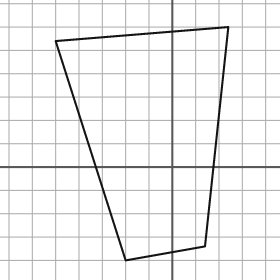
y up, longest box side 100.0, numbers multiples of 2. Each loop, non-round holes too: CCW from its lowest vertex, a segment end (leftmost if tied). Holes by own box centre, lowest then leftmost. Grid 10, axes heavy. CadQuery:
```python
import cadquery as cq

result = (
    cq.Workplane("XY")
    .moveTo(-20.0, -40.0)
    .lineTo(14.0, -34.0)
    .lineTo(24.0, 60.0)
    .lineTo(-50.0, 54.0)
    .close()
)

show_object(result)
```